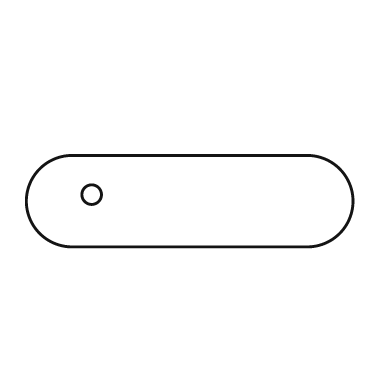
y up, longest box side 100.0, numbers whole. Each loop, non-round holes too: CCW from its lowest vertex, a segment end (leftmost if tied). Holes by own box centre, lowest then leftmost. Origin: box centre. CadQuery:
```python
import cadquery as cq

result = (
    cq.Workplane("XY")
    .moveTo(-36.0, -14.0)
    .lineTo(36.0, -14.0)
    .threePointArc((50.0, 0.0), (36.0, 14.0))
    .lineTo(-36.0, 14.0)
    .threePointArc((-50.0, 0.0), (-36.0, -14.0))
    .close()
    .moveTo(-30.0, 2.0)
    .circle(3.0)
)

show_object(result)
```